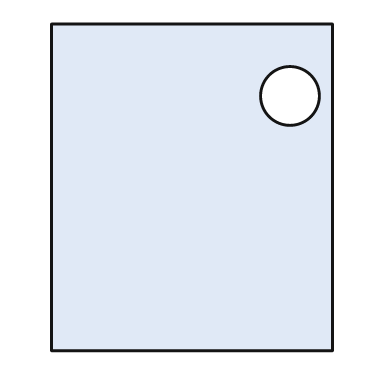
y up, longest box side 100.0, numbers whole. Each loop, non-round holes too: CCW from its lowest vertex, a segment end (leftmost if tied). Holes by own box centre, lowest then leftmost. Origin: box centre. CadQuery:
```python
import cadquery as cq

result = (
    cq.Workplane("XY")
    .moveTo(-43.0, -50.0)
    .lineTo(43.0, -50.0)
    .lineTo(43.0, 50.0)
    .lineTo(-43.0, 50.0)
    .close()
    .moveTo(30.0, 28.0)
    .circle(9.0)
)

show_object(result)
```